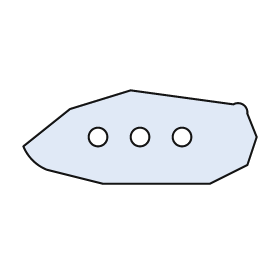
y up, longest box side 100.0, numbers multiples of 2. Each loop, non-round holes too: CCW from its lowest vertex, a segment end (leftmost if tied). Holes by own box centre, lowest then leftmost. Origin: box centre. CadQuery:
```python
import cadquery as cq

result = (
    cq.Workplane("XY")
    .moveTo(-16.0, -20.0)
    .lineTo(30.0, -20.0)
    .lineTo(46.0, -12.0)
    .lineTo(50.0, 0.0)
    .lineTo(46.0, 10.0)
    .threePointArc((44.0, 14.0), (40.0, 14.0))
    .lineTo(-4.0, 20.0)
    .lineTo(-30.0, 12.0)
    .lineTo(-50.0, -4.0)
    .threePointArc((-46.0, -10.0), (-40.0, -14.0))
    .close()
    .moveTo(-18.0, 0.0)
    .circle(4.0)
    .moveTo(0.0, 0.0)
    .circle(4.0)
    .moveTo(18.0, 0.0)
    .circle(4.0)
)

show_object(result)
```